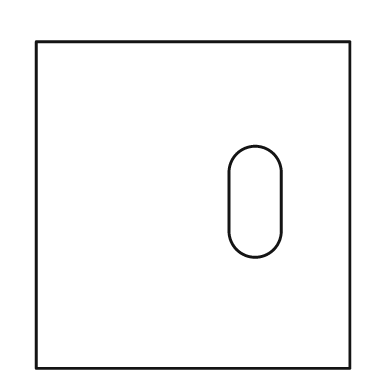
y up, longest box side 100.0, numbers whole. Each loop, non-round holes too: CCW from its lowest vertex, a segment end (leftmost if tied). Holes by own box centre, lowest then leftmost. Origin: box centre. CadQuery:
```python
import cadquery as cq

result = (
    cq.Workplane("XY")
    .moveTo(-48.0, -50.0)
    .lineTo(48.0, -50.0)
    .lineTo(48.0, 50.0)
    .lineTo(-48.0, 50.0)
    .close()
    .moveTo(11.0, -8.0)
    .threePointArc((19.0, -16.0), (27.0, -8.0))
    .lineTo(27.0, 10.0)
    .threePointArc((19.0, 18.0), (11.0, 10.0))
    .close()
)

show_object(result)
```